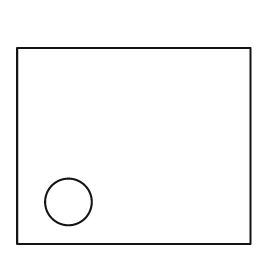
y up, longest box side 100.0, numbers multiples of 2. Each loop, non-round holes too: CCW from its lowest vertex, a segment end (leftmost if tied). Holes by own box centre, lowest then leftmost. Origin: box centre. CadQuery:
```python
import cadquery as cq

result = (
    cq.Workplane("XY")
    .moveTo(-50.0, -42.0)
    .lineTo(50.0, -42.0)
    .lineTo(50.0, 42.0)
    .lineTo(-50.0, 42.0)
    .close()
    .moveTo(-28.0, -24.0)
    .circle(10.0)
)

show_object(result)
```